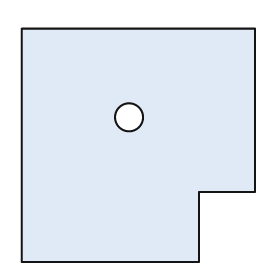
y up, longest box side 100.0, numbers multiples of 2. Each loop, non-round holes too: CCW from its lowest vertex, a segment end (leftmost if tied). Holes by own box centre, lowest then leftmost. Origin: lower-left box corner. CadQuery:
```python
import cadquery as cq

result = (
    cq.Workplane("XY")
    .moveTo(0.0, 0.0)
    .lineTo(76.0, 0.0)
    .lineTo(76.0, 30.0)
    .lineTo(100.0, 30.0)
    .lineTo(100.0, 100.0)
    .lineTo(0.0, 100.0)
    .close()
    .moveTo(46.0, 62.0)
    .circle(6.0)
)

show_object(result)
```